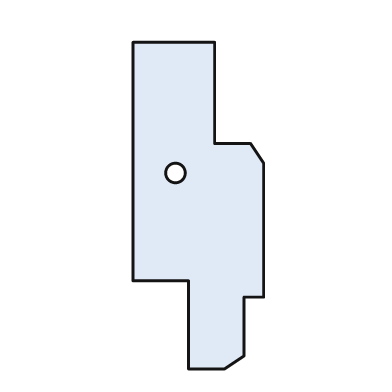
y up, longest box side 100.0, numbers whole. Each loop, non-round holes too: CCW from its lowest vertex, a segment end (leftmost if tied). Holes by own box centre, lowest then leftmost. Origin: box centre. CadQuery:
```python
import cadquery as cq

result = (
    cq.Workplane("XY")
    .moveTo(-3.0, -50.0)
    .lineTo(8.0, -50.0)
    .lineTo(14.0, -46.0)
    .lineTo(14.0, -28.0)
    .lineTo(20.0, -28.0)
    .lineTo(20.0, 13.0)
    .lineTo(16.0, 19.0)
    .lineTo(5.0, 19.0)
    .lineTo(5.0, 50.0)
    .lineTo(-20.0, 50.0)
    .lineTo(-20.0, -23.0)
    .lineTo(-3.0, -23.0)
    .close()
    .moveTo(-7.0, 10.0)
    .circle(3.0)
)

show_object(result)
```